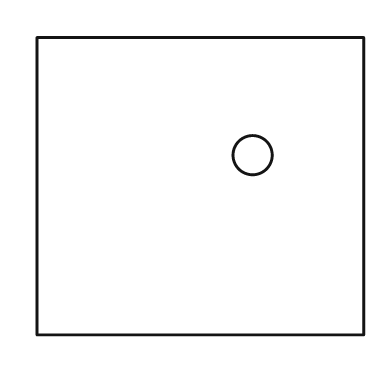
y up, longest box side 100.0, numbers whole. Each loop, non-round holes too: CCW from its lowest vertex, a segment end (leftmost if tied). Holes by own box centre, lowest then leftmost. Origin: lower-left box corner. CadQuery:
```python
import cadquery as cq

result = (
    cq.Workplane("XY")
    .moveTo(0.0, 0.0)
    .lineTo(100.0, 0.0)
    .lineTo(100.0, 91.0)
    .lineTo(0.0, 91.0)
    .close()
    .moveTo(66.0, 55.0)
    .circle(6.0)
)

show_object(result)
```